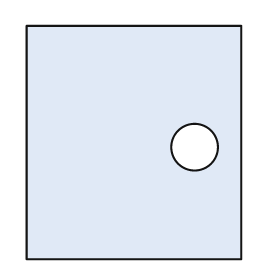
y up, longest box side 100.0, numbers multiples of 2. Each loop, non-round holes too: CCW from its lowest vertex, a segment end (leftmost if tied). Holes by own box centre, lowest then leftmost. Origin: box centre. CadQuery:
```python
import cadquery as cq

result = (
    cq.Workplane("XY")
    .moveTo(-46.0, -50.0)
    .lineTo(46.0, -50.0)
    .lineTo(46.0, 50.0)
    .lineTo(-46.0, 50.0)
    .close()
    .moveTo(26.0, -2.0)
    .circle(10.0)
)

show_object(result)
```